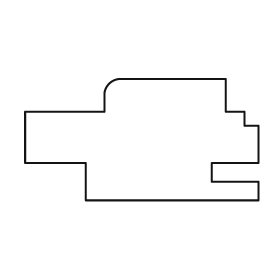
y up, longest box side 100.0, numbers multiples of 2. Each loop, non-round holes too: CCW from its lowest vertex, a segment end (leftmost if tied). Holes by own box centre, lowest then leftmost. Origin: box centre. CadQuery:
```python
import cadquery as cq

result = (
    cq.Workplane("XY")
    .moveTo(-24.0, -26.0)
    .lineTo(50.0, -26.0)
    .lineTo(50.0, -18.0)
    .lineTo(30.0, -18.0)
    .lineTo(30.0, -10.0)
    .lineTo(50.0, -10.0)
    .lineTo(50.0, 6.0)
    .lineTo(44.0, 6.0)
    .lineTo(44.0, 12.0)
    .lineTo(36.0, 12.0)
    .lineTo(36.0, 26.0)
    .lineTo(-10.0, 26.0)
    .threePointArc((-14.0, 24.0), (-16.0, 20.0))
    .lineTo(-16.0, 12.0)
    .lineTo(-50.0, 12.0)
    .lineTo(-50.0, -10.0)
    .lineTo(-24.0, -10.0)
    .close()
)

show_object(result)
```